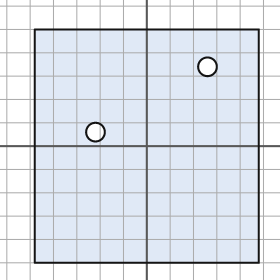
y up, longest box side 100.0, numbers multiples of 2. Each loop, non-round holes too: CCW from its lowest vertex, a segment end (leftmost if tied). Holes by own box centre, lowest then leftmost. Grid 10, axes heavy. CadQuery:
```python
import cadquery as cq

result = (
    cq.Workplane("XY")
    .moveTo(-48.0, -50.0)
    .lineTo(48.0, -50.0)
    .lineTo(48.0, 50.0)
    .lineTo(-48.0, 50.0)
    .close()
    .moveTo(-22.0, 6.0)
    .circle(4.0)
    .moveTo(26.0, 34.0)
    .circle(4.0)
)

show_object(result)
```